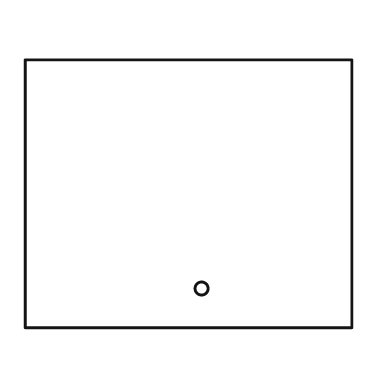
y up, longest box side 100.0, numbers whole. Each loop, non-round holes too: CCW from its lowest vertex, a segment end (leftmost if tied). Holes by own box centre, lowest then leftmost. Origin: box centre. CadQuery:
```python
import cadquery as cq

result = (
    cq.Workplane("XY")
    .moveTo(-50.0, -41.0)
    .lineTo(50.0, -41.0)
    .lineTo(50.0, 41.0)
    .lineTo(-50.0, 41.0)
    .close()
    .moveTo(4.0, -29.0)
    .circle(2.0)
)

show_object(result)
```